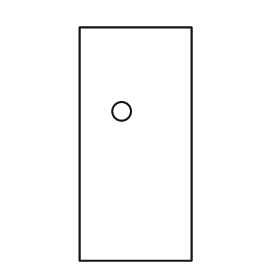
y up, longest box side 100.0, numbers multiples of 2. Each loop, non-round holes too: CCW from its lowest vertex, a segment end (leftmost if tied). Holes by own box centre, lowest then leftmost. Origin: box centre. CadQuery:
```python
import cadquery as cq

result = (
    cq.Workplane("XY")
    .moveTo(-24.0, -50.0)
    .lineTo(24.0, -50.0)
    .lineTo(24.0, 50.0)
    .lineTo(-24.0, 50.0)
    .close()
    .moveTo(-6.0, 14.0)
    .circle(4.0)
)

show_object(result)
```